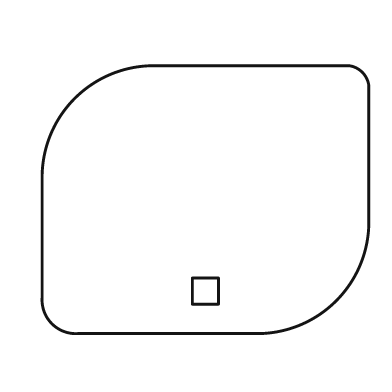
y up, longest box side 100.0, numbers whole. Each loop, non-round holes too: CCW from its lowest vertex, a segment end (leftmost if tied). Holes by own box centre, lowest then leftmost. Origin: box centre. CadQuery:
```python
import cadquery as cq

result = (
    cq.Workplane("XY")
    .moveTo(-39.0, -41.0)
    .lineTo(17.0, -41.0)
    .threePointArc((40.0, -31.0), (50.0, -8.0))
    .lineTo(50.0, 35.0)
    .threePointArc((48.0, 39.0), (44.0, 41.0))
    .lineTo(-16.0, 41.0)
    .threePointArc((-40.0, 31.0), (-50.0, 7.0))
    .lineTo(-50.0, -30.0)
    .threePointArc((-47.0, -38.0), (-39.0, -41.0))
    .close()
    .moveTo(-4.0, -32.0)
    .lineTo(4.0, -32.0)
    .lineTo(4.0, -24.0)
    .lineTo(-4.0, -24.0)
    .close()
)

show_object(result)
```